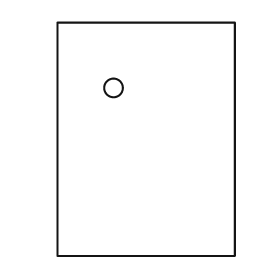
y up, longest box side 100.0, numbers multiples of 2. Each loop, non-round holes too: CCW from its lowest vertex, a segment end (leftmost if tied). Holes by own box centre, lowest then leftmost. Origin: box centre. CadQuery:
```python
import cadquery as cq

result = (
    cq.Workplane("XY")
    .moveTo(-38.0, -50.0)
    .lineTo(38.0, -50.0)
    .lineTo(38.0, 50.0)
    .lineTo(-38.0, 50.0)
    .close()
    .moveTo(-14.0, 22.0)
    .circle(4.0)
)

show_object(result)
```